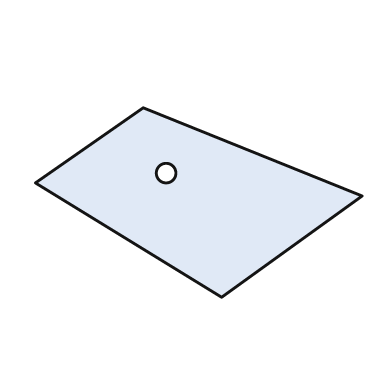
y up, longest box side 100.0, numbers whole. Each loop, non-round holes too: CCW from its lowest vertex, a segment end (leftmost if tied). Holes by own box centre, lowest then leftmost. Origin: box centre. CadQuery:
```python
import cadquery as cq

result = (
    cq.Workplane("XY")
    .moveTo(7.0, -29.0)
    .lineTo(50.0, 2.0)
    .lineTo(-17.0, 29.0)
    .lineTo(-50.0, 6.0)
    .close()
    .moveTo(-10.0, 9.0)
    .circle(3.0)
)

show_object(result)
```